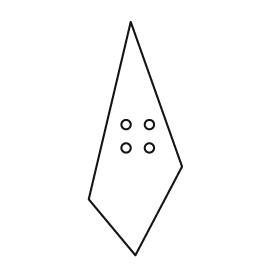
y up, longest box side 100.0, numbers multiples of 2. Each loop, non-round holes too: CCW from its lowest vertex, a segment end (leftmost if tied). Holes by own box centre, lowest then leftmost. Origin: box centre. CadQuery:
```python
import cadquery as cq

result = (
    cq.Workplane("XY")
    .moveTo(0.0, -50.0)
    .lineTo(20.0, -12.0)
    .lineTo(-2.0, 50.0)
    .lineTo(-20.0, -26.0)
    .close()
    .moveTo(-4.0, -4.0)
    .circle(2.0)
    .moveTo(6.0, -4.0)
    .circle(2.0)
    .moveTo(-4.0, 6.0)
    .circle(2.0)
    .moveTo(6.0, 6.0)
    .circle(2.0)
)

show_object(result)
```